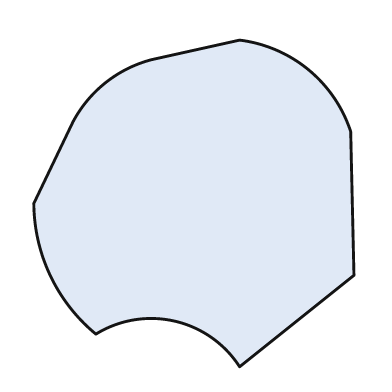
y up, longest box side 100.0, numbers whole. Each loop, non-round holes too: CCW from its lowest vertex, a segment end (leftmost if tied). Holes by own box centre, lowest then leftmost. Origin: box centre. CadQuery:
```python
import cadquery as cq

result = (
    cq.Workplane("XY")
    .moveTo(14.0, -50.0)
    .lineTo(49.0, -22.0)
    .lineTo(48.0, 22.0)
    .threePointArc((35.0, 41.0), (14.0, 50.0))
    .lineTo(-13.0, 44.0)
    .threePointArc((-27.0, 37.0), (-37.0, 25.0))
    .lineTo(-49.0, 0.0)
    .threePointArc((-44.0, -22.0), (-30.0, -40.0))
    .threePointArc((-6.0, -36.0), (14.0, -50.0))
    .close()
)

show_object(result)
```